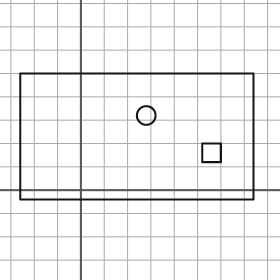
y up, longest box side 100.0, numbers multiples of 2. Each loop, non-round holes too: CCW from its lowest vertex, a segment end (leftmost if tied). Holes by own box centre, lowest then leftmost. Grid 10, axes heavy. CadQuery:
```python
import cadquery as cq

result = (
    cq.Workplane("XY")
    .moveTo(-26.0, -4.0)
    .lineTo(74.0, -4.0)
    .lineTo(74.0, 50.0)
    .lineTo(-26.0, 50.0)
    .close()
    .moveTo(52.0, 12.0)
    .lineTo(60.0, 12.0)
    .lineTo(60.0, 20.0)
    .lineTo(52.0, 20.0)
    .close()
    .moveTo(28.0, 32.0)
    .circle(4.0)
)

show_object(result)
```